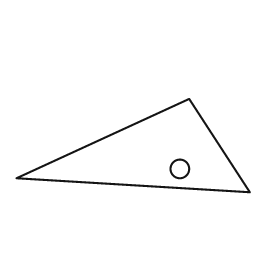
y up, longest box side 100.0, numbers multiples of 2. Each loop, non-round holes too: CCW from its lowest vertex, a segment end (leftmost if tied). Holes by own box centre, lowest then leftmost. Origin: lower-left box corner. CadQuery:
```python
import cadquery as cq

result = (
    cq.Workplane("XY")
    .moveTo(100.0, 0.0)
    .lineTo(74.0, 40.0)
    .lineTo(0.0, 6.0)
    .close()
    .moveTo(70.0, 10.0)
    .circle(4.0)
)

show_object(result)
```